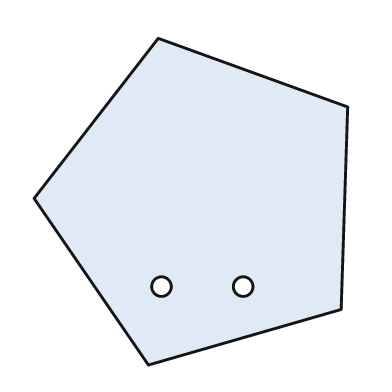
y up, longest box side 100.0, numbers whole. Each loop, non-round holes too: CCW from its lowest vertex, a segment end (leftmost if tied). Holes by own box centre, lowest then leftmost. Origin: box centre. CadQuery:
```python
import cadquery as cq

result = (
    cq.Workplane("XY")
    .moveTo(-13.0, -50.0)
    .lineTo(46.0, -33.0)
    .lineTo(48.0, 29.0)
    .lineTo(-10.0, 50.0)
    .lineTo(-48.0, 1.0)
    .close()
    .moveTo(-9.0, -26.0)
    .circle(3.0)
    .moveTo(16.0, -26.0)
    .circle(3.0)
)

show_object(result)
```